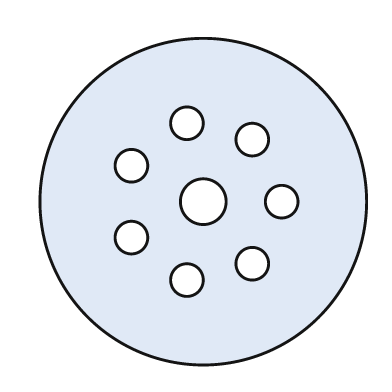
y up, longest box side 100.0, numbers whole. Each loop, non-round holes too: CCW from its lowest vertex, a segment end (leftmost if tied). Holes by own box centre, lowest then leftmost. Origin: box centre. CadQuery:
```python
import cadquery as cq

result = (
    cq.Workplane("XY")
    .moveTo(0.0, 0.0)
    .circle(50.0)
    .moveTo(-5.0, -24.0)
    .circle(5.0)
    .moveTo(15.0, -19.0)
    .circle(5.0)
    .moveTo(-22.0, -11.0)
    .circle(5.0)
    .moveTo(0.0, 0.0)
    .circle(7.0)
    .moveTo(24.0, 0.0)
    .circle(5.0)
    .moveTo(-22.0, 11.0)
    .circle(5.0)
    .moveTo(15.0, 19.0)
    .circle(5.0)
    .moveTo(-5.0, 24.0)
    .circle(5.0)
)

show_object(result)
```